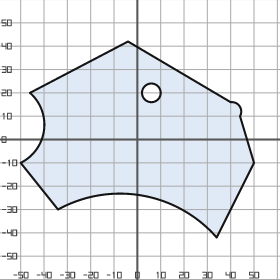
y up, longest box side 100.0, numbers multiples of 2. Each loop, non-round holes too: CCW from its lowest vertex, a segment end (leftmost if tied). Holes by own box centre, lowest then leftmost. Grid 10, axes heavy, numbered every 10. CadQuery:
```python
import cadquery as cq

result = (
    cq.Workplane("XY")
    .moveTo(34.0, -42.0)
    .lineTo(50.0, -10.0)
    .lineTo(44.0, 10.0)
    .threePointArc((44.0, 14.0), (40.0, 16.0))
    .lineTo(-4.0, 42.0)
    .lineTo(-46.0, 20.0)
    .threePointArc((-40.0, 4.0), (-50.0, -10.0))
    .lineTo(-34.0, -30.0)
    .threePointArc((2.0, -24.0), (34.0, -42.0))
    .close()
    .moveTo(6.0, 20.0)
    .circle(4.0)
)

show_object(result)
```